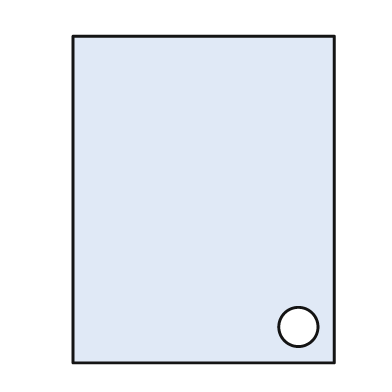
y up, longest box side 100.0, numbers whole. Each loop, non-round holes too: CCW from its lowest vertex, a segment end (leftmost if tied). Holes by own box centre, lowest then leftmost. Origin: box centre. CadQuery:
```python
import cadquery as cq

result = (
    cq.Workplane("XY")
    .moveTo(-40.0, -50.0)
    .lineTo(40.0, -50.0)
    .lineTo(40.0, 50.0)
    .lineTo(-40.0, 50.0)
    .close()
    .moveTo(29.0, -39.0)
    .circle(6.0)
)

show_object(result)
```